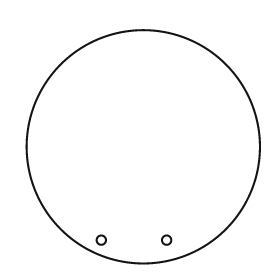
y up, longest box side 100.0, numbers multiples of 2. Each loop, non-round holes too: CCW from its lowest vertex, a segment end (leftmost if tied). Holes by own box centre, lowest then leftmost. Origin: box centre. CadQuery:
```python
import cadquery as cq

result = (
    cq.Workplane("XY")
    .moveTo(0.0, 0.0)
    .circle(50.0)
    .moveTo(-18.0, -40.0)
    .circle(2.0)
    .moveTo(10.0, -40.0)
    .circle(2.0)
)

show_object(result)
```